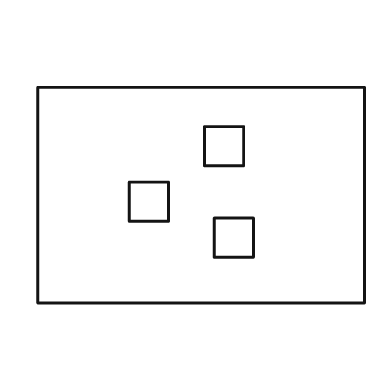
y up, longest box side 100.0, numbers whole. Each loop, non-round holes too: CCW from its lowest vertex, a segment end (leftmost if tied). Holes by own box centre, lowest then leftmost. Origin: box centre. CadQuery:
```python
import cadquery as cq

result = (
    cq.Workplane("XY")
    .moveTo(-50.0, -33.0)
    .lineTo(50.0, -33.0)
    .lineTo(50.0, 33.0)
    .lineTo(-50.0, 33.0)
    .close()
    .moveTo(4.0, -19.0)
    .lineTo(16.0, -19.0)
    .lineTo(16.0, -7.0)
    .lineTo(4.0, -7.0)
    .close()
    .moveTo(-22.0, -8.0)
    .lineTo(-10.0, -8.0)
    .lineTo(-10.0, 4.0)
    .lineTo(-22.0, 4.0)
    .close()
    .moveTo(1.0, 9.0)
    .lineTo(13.0, 9.0)
    .lineTo(13.0, 21.0)
    .lineTo(1.0, 21.0)
    .close()
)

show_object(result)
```